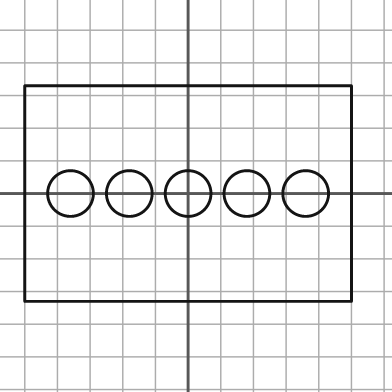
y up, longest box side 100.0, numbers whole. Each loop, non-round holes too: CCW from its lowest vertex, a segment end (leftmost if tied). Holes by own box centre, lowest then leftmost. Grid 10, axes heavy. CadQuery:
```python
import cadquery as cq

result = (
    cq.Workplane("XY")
    .moveTo(-50.0, -33.0)
    .lineTo(50.0, -33.0)
    .lineTo(50.0, 33.0)
    .lineTo(-50.0, 33.0)
    .close()
    .moveTo(-36.0, 0.0)
    .circle(7.0)
    .moveTo(-18.0, 0.0)
    .circle(7.0)
    .moveTo(0.0, 0.0)
    .circle(7.0)
    .moveTo(18.0, 0.0)
    .circle(7.0)
    .moveTo(36.0, 0.0)
    .circle(7.0)
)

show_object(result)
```